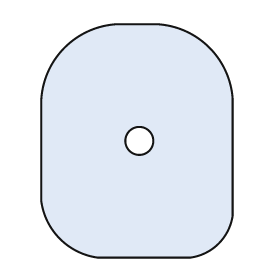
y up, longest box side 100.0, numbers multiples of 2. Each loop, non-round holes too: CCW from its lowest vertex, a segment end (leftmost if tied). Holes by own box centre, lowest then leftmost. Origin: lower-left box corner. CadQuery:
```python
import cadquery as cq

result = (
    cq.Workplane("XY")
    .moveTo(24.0, 0.0)
    .lineTo(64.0, 0.0)
    .threePointArc((76.0, 6.0), (82.0, 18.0))
    .lineTo(82.0, 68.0)
    .threePointArc((72.0, 90.0), (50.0, 100.0))
    .lineTo(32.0, 100.0)
    .threePointArc((10.0, 90.0), (0.0, 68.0))
    .lineTo(0.0, 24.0)
    .threePointArc((8.0, 8.0), (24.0, 0.0))
    .close()
    .moveTo(42.0, 50.0)
    .circle(6.0)
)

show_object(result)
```